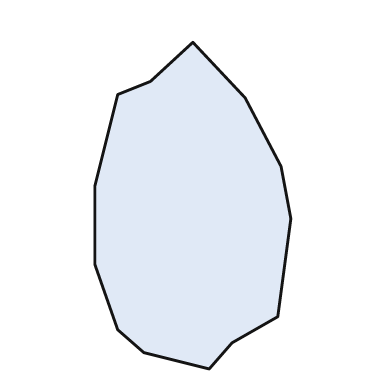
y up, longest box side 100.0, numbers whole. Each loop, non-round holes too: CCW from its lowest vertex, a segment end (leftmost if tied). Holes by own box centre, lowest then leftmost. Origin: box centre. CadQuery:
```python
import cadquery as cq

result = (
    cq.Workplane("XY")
    .moveTo(5.0, -50.0)
    .lineTo(12.0, -42.0)
    .lineTo(26.0, -34.0)
    .lineTo(30.0, -4.0)
    .lineTo(27.0, 12.0)
    .lineTo(16.0, 33.0)
    .lineTo(0.0, 50.0)
    .lineTo(-13.0, 38.0)
    .lineTo(-23.0, 34.0)
    .lineTo(-30.0, 6.0)
    .lineTo(-30.0, -18.0)
    .lineTo(-23.0, -38.0)
    .lineTo(-15.0, -45.0)
    .close()
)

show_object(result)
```